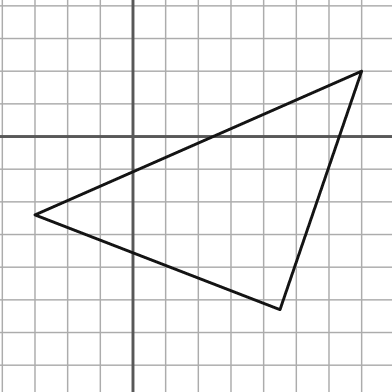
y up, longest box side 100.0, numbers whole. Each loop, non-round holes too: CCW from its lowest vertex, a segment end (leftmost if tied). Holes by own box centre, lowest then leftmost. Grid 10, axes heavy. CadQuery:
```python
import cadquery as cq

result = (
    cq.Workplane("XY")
    .moveTo(45.0, -53.0)
    .lineTo(70.0, 20.0)
    .lineTo(-30.0, -24.0)
    .close()
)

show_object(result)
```